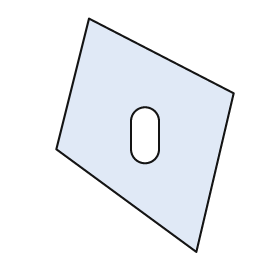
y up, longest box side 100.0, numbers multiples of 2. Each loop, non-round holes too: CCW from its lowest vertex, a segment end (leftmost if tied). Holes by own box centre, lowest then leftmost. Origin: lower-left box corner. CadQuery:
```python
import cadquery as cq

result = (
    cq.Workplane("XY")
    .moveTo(60.0, 0.0)
    .lineTo(76.0, 68.0)
    .lineTo(14.0, 100.0)
    .lineTo(0.0, 44.0)
    .close()
    .moveTo(32.0, 44.0)
    .threePointArc((38.0, 38.0), (44.0, 44.0))
    .lineTo(44.0, 56.0)
    .threePointArc((38.0, 62.0), (32.0, 56.0))
    .close()
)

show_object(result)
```